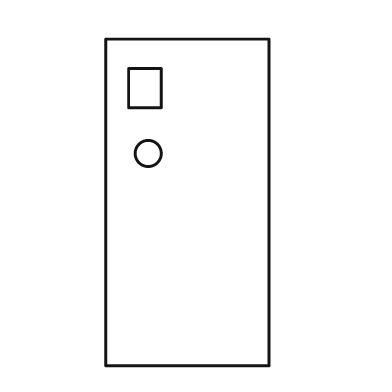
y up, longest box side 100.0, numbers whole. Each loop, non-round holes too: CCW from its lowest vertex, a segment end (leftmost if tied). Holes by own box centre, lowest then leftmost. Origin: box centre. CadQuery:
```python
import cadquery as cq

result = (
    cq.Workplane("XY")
    .moveTo(-25.0, -50.0)
    .lineTo(25.0, -50.0)
    .lineTo(25.0, 50.0)
    .lineTo(-25.0, 50.0)
    .close()
    .moveTo(-12.0, 15.0)
    .circle(4.0)
    .moveTo(-18.0, 29.0)
    .lineTo(-8.0, 29.0)
    .lineTo(-8.0, 41.0)
    .lineTo(-18.0, 41.0)
    .close()
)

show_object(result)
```